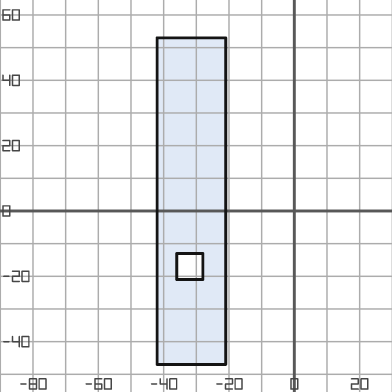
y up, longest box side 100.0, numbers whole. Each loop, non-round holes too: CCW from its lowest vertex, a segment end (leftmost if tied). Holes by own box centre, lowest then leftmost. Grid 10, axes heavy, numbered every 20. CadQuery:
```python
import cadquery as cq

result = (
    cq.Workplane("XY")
    .moveTo(-42.0, -47.0)
    .lineTo(-21.0, -47.0)
    .lineTo(-21.0, 53.0)
    .lineTo(-42.0, 53.0)
    .close()
    .moveTo(-36.0, -21.0)
    .lineTo(-28.0, -21.0)
    .lineTo(-28.0, -13.0)
    .lineTo(-36.0, -13.0)
    .close()
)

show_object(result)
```